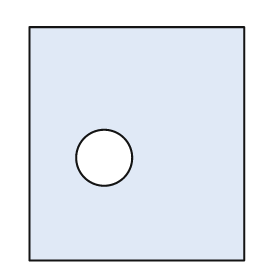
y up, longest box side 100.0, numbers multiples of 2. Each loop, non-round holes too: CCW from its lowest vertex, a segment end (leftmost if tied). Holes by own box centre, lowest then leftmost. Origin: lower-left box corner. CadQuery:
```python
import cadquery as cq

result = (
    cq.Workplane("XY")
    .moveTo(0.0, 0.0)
    .lineTo(92.0, 0.0)
    .lineTo(92.0, 100.0)
    .lineTo(0.0, 100.0)
    .close()
    .moveTo(32.0, 44.0)
    .circle(12.0)
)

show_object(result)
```